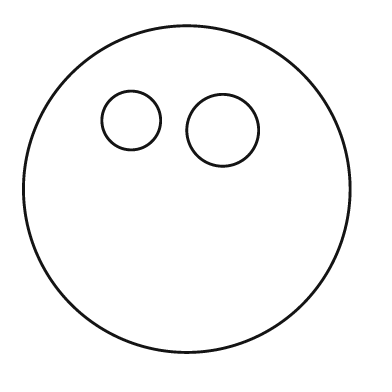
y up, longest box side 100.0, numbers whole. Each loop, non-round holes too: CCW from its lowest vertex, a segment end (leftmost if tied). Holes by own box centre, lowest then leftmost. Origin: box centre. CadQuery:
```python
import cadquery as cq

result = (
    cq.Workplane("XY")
    .moveTo(0.0, 0.0)
    .circle(50.0)
    .moveTo(11.0, 18.0)
    .circle(11.0)
    .moveTo(-17.0, 21.0)
    .circle(9.0)
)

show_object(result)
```